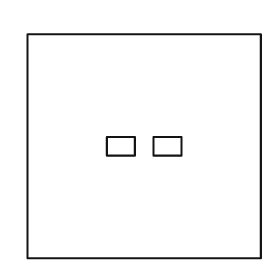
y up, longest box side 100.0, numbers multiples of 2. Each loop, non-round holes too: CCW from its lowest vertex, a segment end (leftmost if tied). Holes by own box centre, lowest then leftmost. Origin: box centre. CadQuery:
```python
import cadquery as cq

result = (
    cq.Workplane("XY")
    .moveTo(-50.0, -48.0)
    .lineTo(50.0, -48.0)
    .lineTo(50.0, 48.0)
    .lineTo(-50.0, 48.0)
    .close()
    .moveTo(-16.0, -4.0)
    .lineTo(-4.0, -4.0)
    .lineTo(-4.0, 4.0)
    .lineTo(-16.0, 4.0)
    .close()
    .moveTo(4.0, -4.0)
    .lineTo(16.0, -4.0)
    .lineTo(16.0, 4.0)
    .lineTo(4.0, 4.0)
    .close()
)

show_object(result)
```